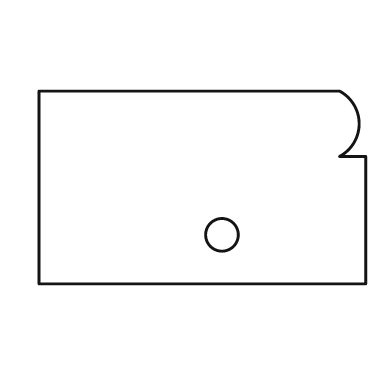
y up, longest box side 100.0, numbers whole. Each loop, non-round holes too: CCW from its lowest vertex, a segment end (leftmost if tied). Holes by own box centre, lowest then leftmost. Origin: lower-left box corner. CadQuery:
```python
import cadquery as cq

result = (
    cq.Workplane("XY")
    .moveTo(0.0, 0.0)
    .lineTo(100.0, 0.0)
    .lineTo(100.0, 39.0)
    .lineTo(92.0, 39.0)
    .threePointArc((98.0, 49.0), (92.0, 59.0))
    .lineTo(0.0, 59.0)
    .close()
    .moveTo(56.0, 15.0)
    .circle(5.0)
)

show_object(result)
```